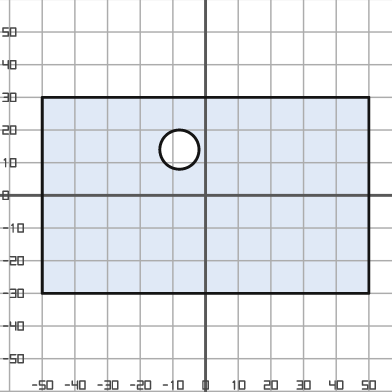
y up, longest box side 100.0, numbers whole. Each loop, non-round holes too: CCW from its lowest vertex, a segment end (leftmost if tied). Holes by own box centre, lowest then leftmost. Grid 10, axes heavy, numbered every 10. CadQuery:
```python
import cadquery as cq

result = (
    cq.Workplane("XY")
    .moveTo(-50.0, -30.0)
    .lineTo(50.0, -30.0)
    .lineTo(50.0, 30.0)
    .lineTo(-50.0, 30.0)
    .close()
    .moveTo(-8.0, 14.0)
    .circle(6.0)
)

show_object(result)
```